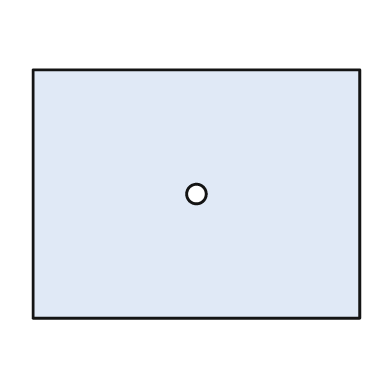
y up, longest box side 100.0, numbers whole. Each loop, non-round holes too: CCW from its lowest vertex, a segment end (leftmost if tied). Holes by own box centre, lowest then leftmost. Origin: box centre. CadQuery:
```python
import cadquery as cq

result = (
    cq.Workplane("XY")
    .moveTo(-50.0, -38.0)
    .lineTo(50.0, -38.0)
    .lineTo(50.0, 38.0)
    .lineTo(-50.0, 38.0)
    .close()
    .moveTo(0.0, 0.0)
    .circle(3.0)
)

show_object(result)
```